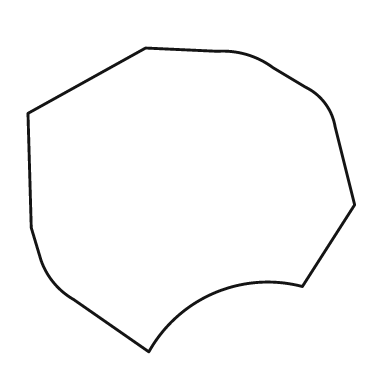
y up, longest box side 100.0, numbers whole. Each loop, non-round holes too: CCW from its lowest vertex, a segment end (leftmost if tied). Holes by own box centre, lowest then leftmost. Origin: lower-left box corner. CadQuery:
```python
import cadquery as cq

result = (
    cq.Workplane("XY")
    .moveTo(37.0, 0.0)
    .threePointArc((57.0, 18.0), (84.0, 20.0))
    .lineTo(100.0, 45.0)
    .lineTo(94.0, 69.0)
    .threePointArc((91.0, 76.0), (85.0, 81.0))
    .lineTo(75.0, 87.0)
    .threePointArc((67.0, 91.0), (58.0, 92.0))
    .lineTo(36.0, 93.0)
    .lineTo(0.0, 73.0)
    .lineTo(1.0, 38.0)
    .lineTo(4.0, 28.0)
    .threePointArc((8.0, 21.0), (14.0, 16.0))
    .close()
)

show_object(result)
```